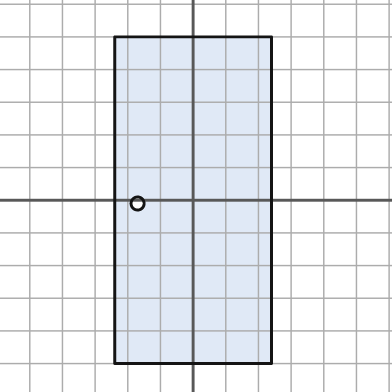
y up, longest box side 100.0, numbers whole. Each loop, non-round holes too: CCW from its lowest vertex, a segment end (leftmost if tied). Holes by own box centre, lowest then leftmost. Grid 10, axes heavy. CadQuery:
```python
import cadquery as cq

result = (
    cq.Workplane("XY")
    .moveTo(-24.0, -50.0)
    .lineTo(24.0, -50.0)
    .lineTo(24.0, 50.0)
    .lineTo(-24.0, 50.0)
    .close()
    .moveTo(-17.0, -1.0)
    .circle(2.0)
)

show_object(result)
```